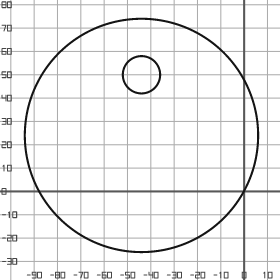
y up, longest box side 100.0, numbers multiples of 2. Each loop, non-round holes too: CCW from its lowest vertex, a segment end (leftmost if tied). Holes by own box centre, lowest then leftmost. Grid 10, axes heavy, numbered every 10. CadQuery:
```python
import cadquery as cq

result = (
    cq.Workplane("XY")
    .moveTo(-44.0, 24.0)
    .circle(50.0)
    .moveTo(-44.0, 50.0)
    .circle(8.0)
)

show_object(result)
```